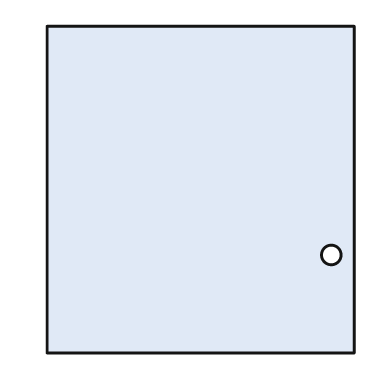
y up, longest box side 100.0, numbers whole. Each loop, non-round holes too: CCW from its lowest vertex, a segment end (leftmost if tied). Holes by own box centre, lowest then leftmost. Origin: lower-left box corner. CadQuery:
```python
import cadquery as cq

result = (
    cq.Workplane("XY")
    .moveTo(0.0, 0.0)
    .lineTo(94.0, 0.0)
    .lineTo(94.0, 100.0)
    .lineTo(0.0, 100.0)
    .close()
    .moveTo(87.0, 30.0)
    .circle(3.0)
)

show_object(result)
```